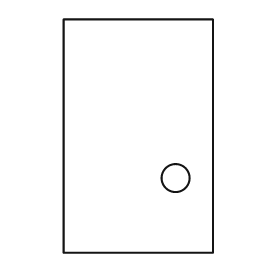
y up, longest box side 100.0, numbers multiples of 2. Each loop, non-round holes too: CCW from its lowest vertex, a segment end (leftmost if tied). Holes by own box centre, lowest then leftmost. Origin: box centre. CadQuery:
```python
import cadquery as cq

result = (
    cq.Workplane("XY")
    .moveTo(-32.0, -50.0)
    .lineTo(32.0, -50.0)
    .lineTo(32.0, 50.0)
    .lineTo(-32.0, 50.0)
    .close()
    .moveTo(16.0, -18.0)
    .circle(6.0)
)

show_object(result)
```